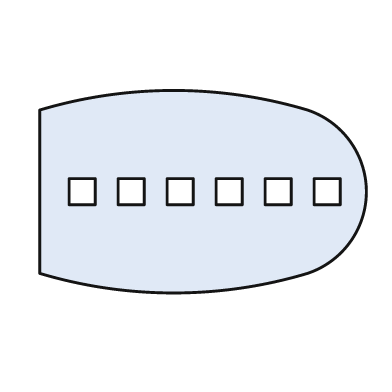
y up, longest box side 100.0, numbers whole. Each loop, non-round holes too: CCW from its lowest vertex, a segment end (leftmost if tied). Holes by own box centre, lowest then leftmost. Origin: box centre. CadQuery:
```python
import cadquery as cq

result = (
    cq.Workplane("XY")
    .moveTo(-50.0, -25.0)
    .threePointArc((-9.0, -31.0), (32.0, -25.0))
    .threePointArc((50.0, 0.0), (32.0, 25.0))
    .threePointArc((-9.0, 31.0), (-50.0, 25.0))
    .close()
    .moveTo(-41.0, -4.0)
    .lineTo(-33.0, -4.0)
    .lineTo(-33.0, 4.0)
    .lineTo(-41.0, 4.0)
    .close()
    .moveTo(-26.0, -4.0)
    .lineTo(-18.0, -4.0)
    .lineTo(-18.0, 4.0)
    .lineTo(-26.0, 4.0)
    .close()
    .moveTo(-11.0, -4.0)
    .lineTo(-3.0, -4.0)
    .lineTo(-3.0, 4.0)
    .lineTo(-11.0, 4.0)
    .close()
    .moveTo(4.0, -4.0)
    .lineTo(12.0, -4.0)
    .lineTo(12.0, 4.0)
    .lineTo(4.0, 4.0)
    .close()
    .moveTo(19.0, -4.0)
    .lineTo(27.0, -4.0)
    .lineTo(27.0, 4.0)
    .lineTo(19.0, 4.0)
    .close()
    .moveTo(34.0, -4.0)
    .lineTo(42.0, -4.0)
    .lineTo(42.0, 4.0)
    .lineTo(34.0, 4.0)
    .close()
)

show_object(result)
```